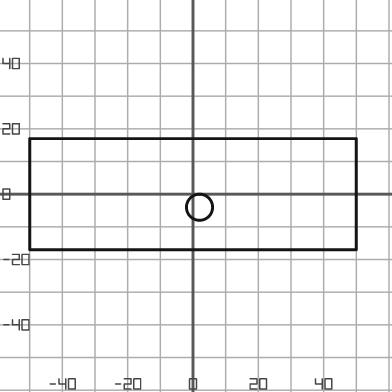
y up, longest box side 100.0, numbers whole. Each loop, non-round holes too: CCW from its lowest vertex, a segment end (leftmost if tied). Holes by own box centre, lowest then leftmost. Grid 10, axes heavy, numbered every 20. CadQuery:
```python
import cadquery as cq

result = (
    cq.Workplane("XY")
    .moveTo(-50.0, -17.0)
    .lineTo(50.0, -17.0)
    .lineTo(50.0, 17.0)
    .lineTo(-50.0, 17.0)
    .close()
    .moveTo(2.0, -4.0)
    .circle(4.0)
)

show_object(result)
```